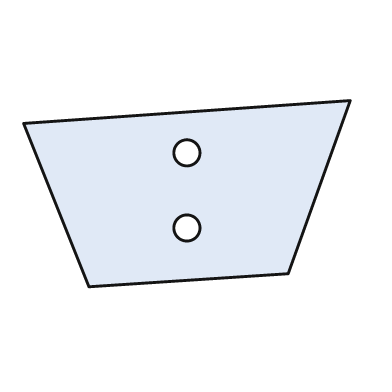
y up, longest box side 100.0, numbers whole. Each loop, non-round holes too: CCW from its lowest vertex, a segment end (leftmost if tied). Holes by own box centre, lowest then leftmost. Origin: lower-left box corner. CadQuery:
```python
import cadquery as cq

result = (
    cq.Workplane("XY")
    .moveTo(20.0, 0.0)
    .lineTo(81.0, 4.0)
    .lineTo(100.0, 57.0)
    .lineTo(0.0, 50.0)
    .close()
    .moveTo(50.0, 18.0)
    .circle(4.0)
    .moveTo(50.0, 41.0)
    .circle(4.0)
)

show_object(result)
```